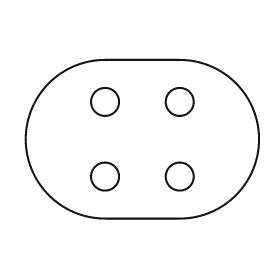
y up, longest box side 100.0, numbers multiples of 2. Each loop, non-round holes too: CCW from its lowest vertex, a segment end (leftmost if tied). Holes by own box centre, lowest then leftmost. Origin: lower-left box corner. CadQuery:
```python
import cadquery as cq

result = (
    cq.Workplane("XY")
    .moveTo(34.0, 0.0)
    .lineTo(66.0, 0.0)
    .threePointArc((100.0, 34.0), (66.0, 68.0))
    .lineTo(34.0, 68.0)
    .threePointArc((0.0, 34.0), (34.0, 0.0))
    .close()
    .moveTo(34.0, 18.0)
    .circle(6.0)
    .moveTo(66.0, 18.0)
    .circle(6.0)
    .moveTo(34.0, 50.0)
    .circle(6.0)
    .moveTo(66.0, 50.0)
    .circle(6.0)
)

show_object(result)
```